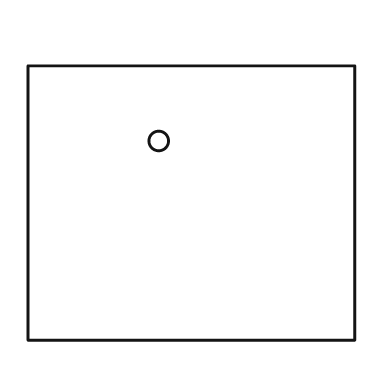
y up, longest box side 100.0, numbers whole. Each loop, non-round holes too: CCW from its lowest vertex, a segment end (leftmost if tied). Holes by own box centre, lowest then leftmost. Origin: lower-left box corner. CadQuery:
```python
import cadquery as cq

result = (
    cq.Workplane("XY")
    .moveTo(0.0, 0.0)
    .lineTo(100.0, 0.0)
    .lineTo(100.0, 84.0)
    .lineTo(0.0, 84.0)
    .close()
    .moveTo(40.0, 61.0)
    .circle(3.0)
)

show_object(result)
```